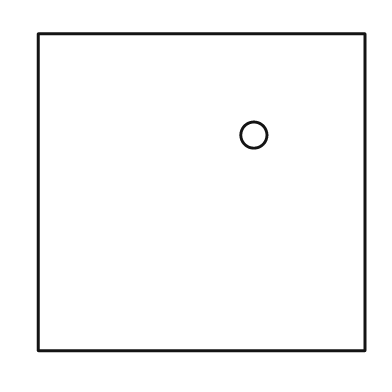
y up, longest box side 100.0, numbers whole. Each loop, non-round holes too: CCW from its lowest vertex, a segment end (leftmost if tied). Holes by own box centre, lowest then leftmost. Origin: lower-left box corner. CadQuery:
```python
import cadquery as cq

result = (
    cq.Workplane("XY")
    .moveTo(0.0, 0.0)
    .lineTo(100.0, 0.0)
    .lineTo(100.0, 97.0)
    .lineTo(0.0, 97.0)
    .close()
    .moveTo(66.0, 66.0)
    .circle(4.0)
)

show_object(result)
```